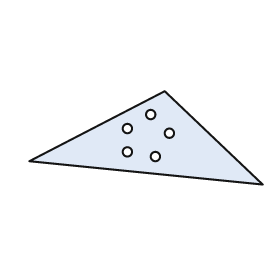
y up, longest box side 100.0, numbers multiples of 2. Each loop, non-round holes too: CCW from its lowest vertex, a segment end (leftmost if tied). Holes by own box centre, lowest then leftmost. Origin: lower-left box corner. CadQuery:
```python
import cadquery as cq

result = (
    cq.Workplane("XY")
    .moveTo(100.0, 0.0)
    .lineTo(58.0, 40.0)
    .lineTo(0.0, 10.0)
    .close()
    .moveTo(54.0, 12.0)
    .circle(2.0)
    .moveTo(42.0, 14.0)
    .circle(2.0)
    .moveTo(60.0, 22.0)
    .circle(2.0)
    .moveTo(42.0, 24.0)
    .circle(2.0)
    .moveTo(52.0, 30.0)
    .circle(2.0)
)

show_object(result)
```